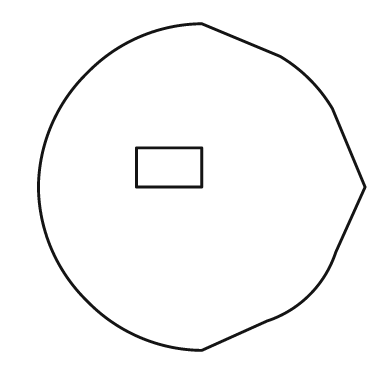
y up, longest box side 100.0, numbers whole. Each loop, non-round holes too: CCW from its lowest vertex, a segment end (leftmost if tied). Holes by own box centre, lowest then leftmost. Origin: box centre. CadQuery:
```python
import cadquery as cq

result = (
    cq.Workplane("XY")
    .moveTo(0.0, -50.0)
    .lineTo(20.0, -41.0)
    .threePointArc((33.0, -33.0), (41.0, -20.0))
    .lineTo(50.0, 0.0)
    .lineTo(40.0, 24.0)
    .threePointArc((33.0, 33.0), (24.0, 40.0))
    .lineTo(0.0, 50.0)
    .threePointArc((-19.0, 46.0), (-35.0, 35.0))
    .threePointArc((-46.0, 19.0), (-50.0, 0.0))
    .threePointArc((-46.0, -19.0), (-35.0, -35.0))
    .threePointArc((-19.0, -46.0), (0.0, -50.0))
    .close()
    .moveTo(-20.0, 0.0)
    .lineTo(0.0, 0.0)
    .lineTo(0.0, 12.0)
    .lineTo(-20.0, 12.0)
    .close()
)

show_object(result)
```